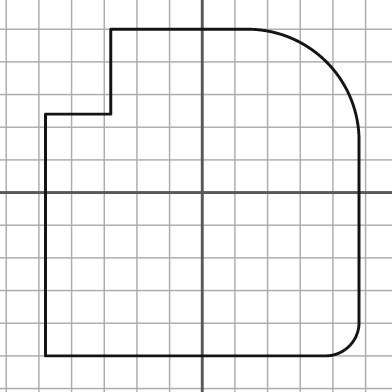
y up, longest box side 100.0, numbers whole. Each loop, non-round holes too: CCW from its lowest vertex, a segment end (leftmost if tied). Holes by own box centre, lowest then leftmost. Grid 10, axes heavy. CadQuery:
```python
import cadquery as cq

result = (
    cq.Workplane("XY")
    .moveTo(-48.0, -50.0)
    .lineTo(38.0, -50.0)
    .threePointArc((45.0, -47.0), (48.0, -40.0))
    .lineTo(48.0, 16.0)
    .threePointArc((38.0, 40.0), (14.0, 50.0))
    .lineTo(-28.0, 50.0)
    .lineTo(-28.0, 24.0)
    .lineTo(-48.0, 24.0)
    .close()
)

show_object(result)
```